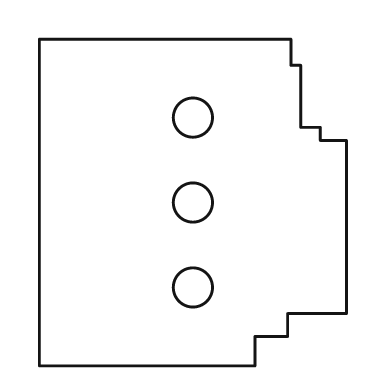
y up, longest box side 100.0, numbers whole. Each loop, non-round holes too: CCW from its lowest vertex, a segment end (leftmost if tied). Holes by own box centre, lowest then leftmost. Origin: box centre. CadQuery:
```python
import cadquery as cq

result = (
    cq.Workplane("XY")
    .moveTo(-47.0, -50.0)
    .lineTo(19.0, -50.0)
    .lineTo(19.0, -41.0)
    .lineTo(29.0, -41.0)
    .lineTo(29.0, -34.0)
    .lineTo(47.0, -34.0)
    .lineTo(47.0, 19.0)
    .lineTo(39.0, 19.0)
    .lineTo(39.0, 23.0)
    .lineTo(33.0, 23.0)
    .lineTo(33.0, 42.0)
    .lineTo(30.0, 42.0)
    .lineTo(30.0, 50.0)
    .lineTo(-47.0, 50.0)
    .close()
    .moveTo(0.0, -26.0)
    .circle(6.0)
    .moveTo(0.0, 0.0)
    .circle(6.0)
    .moveTo(0.0, 26.0)
    .circle(6.0)
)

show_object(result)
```